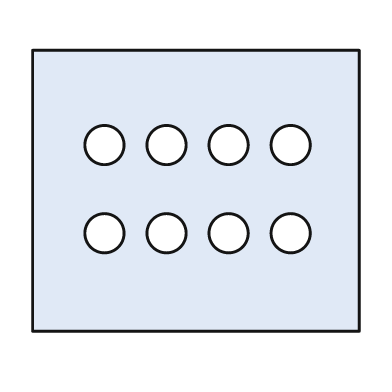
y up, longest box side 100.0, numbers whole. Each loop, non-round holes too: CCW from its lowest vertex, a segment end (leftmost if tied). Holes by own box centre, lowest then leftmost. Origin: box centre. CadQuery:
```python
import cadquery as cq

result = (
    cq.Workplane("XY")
    .moveTo(-50.0, -43.0)
    .lineTo(50.0, -43.0)
    .lineTo(50.0, 43.0)
    .lineTo(-50.0, 43.0)
    .close()
    .moveTo(-28.0, -13.0)
    .circle(6.0)
    .moveTo(-9.0, -13.0)
    .circle(6.0)
    .moveTo(10.0, -13.0)
    .circle(6.0)
    .moveTo(29.0, -13.0)
    .circle(6.0)
    .moveTo(-28.0, 14.0)
    .circle(6.0)
    .moveTo(-9.0, 14.0)
    .circle(6.0)
    .moveTo(10.0, 14.0)
    .circle(6.0)
    .moveTo(29.0, 14.0)
    .circle(6.0)
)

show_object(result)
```